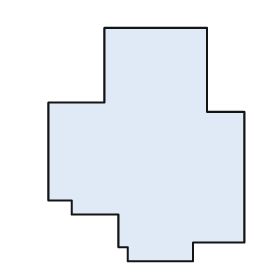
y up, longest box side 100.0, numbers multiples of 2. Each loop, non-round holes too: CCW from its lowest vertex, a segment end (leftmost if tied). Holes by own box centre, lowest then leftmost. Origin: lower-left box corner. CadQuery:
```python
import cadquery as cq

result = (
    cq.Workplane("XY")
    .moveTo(34.0, 0.0)
    .lineTo(62.0, 0.0)
    .lineTo(62.0, 8.0)
    .lineTo(84.0, 8.0)
    .lineTo(84.0, 64.0)
    .lineTo(68.0, 64.0)
    .lineTo(68.0, 100.0)
    .lineTo(24.0, 100.0)
    .lineTo(24.0, 68.0)
    .lineTo(0.0, 68.0)
    .lineTo(0.0, 26.0)
    .lineTo(10.0, 26.0)
    .lineTo(10.0, 20.0)
    .lineTo(30.0, 20.0)
    .lineTo(30.0, 6.0)
    .lineTo(34.0, 6.0)
    .close()
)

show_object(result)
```